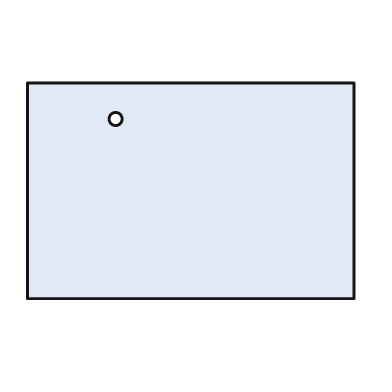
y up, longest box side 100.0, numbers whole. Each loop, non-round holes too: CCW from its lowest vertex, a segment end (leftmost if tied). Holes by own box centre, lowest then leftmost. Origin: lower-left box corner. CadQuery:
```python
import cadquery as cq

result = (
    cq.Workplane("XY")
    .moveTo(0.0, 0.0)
    .lineTo(100.0, 0.0)
    .lineTo(100.0, 66.0)
    .lineTo(0.0, 66.0)
    .close()
    .moveTo(27.0, 55.0)
    .circle(2.0)
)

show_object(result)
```